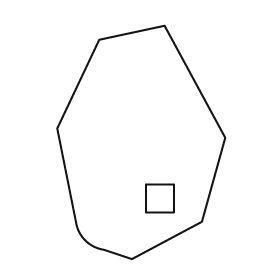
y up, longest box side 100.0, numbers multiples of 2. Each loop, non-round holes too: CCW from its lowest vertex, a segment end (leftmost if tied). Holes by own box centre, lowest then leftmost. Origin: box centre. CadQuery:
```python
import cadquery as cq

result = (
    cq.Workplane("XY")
    .moveTo(-4.0, -50.0)
    .lineTo(26.0, -34.0)
    .lineTo(36.0, 2.0)
    .lineTo(10.0, 50.0)
    .lineTo(-18.0, 44.0)
    .lineTo(-36.0, 6.0)
    .lineTo(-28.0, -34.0)
    .threePointArc((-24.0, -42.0), (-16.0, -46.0))
    .close()
    .moveTo(2.0, -30.0)
    .lineTo(14.0, -30.0)
    .lineTo(14.0, -18.0)
    .lineTo(2.0, -18.0)
    .close()
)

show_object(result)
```